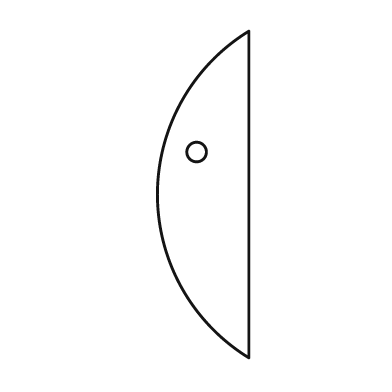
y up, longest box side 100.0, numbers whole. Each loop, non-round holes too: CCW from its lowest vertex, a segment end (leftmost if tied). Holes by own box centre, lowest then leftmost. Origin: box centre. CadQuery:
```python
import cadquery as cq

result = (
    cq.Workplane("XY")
    .moveTo(14.0, -50.0)
    .lineTo(14.0, 50.0)
    .threePointArc((-14.0, 0.0), (14.0, -50.0))
    .close()
    .moveTo(-2.0, 13.0)
    .circle(3.0)
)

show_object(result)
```